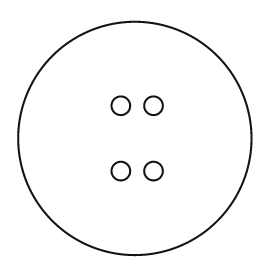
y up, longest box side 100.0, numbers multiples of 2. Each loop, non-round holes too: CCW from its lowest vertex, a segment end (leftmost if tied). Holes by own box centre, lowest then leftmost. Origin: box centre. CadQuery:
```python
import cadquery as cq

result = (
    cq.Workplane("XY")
    .moveTo(0.0, 0.0)
    .circle(50.0)
    .moveTo(-6.0, -14.0)
    .circle(4.0)
    .moveTo(8.0, -14.0)
    .circle(4.0)
    .moveTo(-6.0, 14.0)
    .circle(4.0)
    .moveTo(8.0, 14.0)
    .circle(4.0)
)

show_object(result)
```